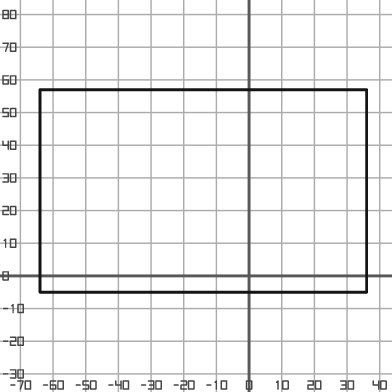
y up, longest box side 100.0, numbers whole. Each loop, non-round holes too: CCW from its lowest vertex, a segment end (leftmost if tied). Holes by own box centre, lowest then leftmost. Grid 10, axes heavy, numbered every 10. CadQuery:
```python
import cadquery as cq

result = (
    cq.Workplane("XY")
    .moveTo(-64.0, -5.0)
    .lineTo(36.0, -5.0)
    .lineTo(36.0, 57.0)
    .lineTo(-64.0, 57.0)
    .close()
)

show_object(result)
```